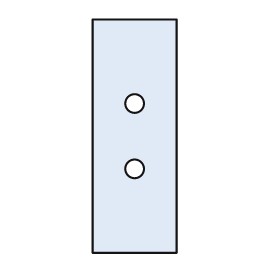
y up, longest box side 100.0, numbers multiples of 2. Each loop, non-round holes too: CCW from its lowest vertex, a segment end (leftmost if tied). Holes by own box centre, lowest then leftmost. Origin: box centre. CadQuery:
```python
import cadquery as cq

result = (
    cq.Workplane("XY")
    .moveTo(-18.0, -50.0)
    .lineTo(18.0, -50.0)
    .lineTo(18.0, 50.0)
    .lineTo(-18.0, 50.0)
    .close()
    .moveTo(0.0, -14.0)
    .circle(4.0)
    .moveTo(0.0, 14.0)
    .circle(4.0)
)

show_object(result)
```